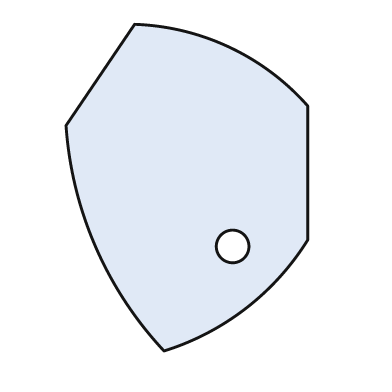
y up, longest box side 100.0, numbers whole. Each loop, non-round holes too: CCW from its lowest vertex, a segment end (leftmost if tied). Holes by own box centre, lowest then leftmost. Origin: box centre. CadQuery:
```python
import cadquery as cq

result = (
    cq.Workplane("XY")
    .moveTo(-7.0, -50.0)
    .threePointArc((18.0, -37.0), (37.0, -16.0))
    .lineTo(37.0, 25.0)
    .threePointArc((13.0, 43.0), (-16.0, 50.0))
    .lineTo(-37.0, 19.0)
    .threePointArc((-28.0, -18.0), (-7.0, -50.0))
    .close()
    .moveTo(14.0, -18.0)
    .circle(5.0)
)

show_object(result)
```